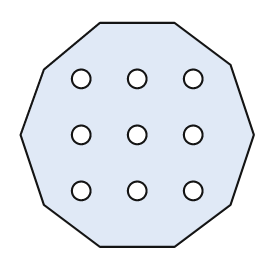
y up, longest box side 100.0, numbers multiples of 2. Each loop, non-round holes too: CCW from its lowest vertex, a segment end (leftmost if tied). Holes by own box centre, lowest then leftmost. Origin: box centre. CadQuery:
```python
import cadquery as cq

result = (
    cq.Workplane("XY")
    .moveTo(-16.0, -48.0)
    .lineTo(16.0, -48.0)
    .lineTo(40.0, -30.0)
    .lineTo(50.0, 0.0)
    .lineTo(40.0, 30.0)
    .lineTo(16.0, 48.0)
    .lineTo(-16.0, 48.0)
    .lineTo(-40.0, 28.0)
    .lineTo(-50.0, 0.0)
    .lineTo(-40.0, -30.0)
    .close()
    .moveTo(-24.0, -24.0)
    .circle(4.0)
    .moveTo(0.0, -24.0)
    .circle(4.0)
    .moveTo(24.0, -24.0)
    .circle(4.0)
    .moveTo(-24.0, 0.0)
    .circle(4.0)
    .moveTo(0.0, 0.0)
    .circle(4.0)
    .moveTo(24.0, 0.0)
    .circle(4.0)
    .moveTo(-24.0, 24.0)
    .circle(4.0)
    .moveTo(0.0, 24.0)
    .circle(4.0)
    .moveTo(24.0, 24.0)
    .circle(4.0)
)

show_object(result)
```